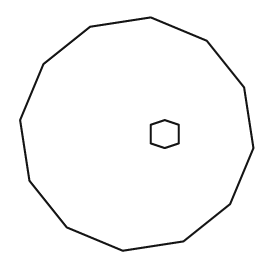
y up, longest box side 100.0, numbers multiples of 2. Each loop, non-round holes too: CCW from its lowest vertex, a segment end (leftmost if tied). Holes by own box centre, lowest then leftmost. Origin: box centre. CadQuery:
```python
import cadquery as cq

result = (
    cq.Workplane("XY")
    .moveTo(-6.0, -50.0)
    .lineTo(20.0, -46.0)
    .lineTo(40.0, -30.0)
    .lineTo(50.0, -6.0)
    .lineTo(46.0, 20.0)
    .lineTo(30.0, 40.0)
    .lineTo(6.0, 50.0)
    .lineTo(-20.0, 46.0)
    .lineTo(-40.0, 30.0)
    .lineTo(-50.0, 6.0)
    .lineTo(-46.0, -20.0)
    .lineTo(-30.0, -40.0)
    .close()
    .moveTo(12.0, -6.0)
    .lineTo(18.0, -4.0)
    .lineTo(18.0, 4.0)
    .lineTo(12.0, 6.0)
    .lineTo(6.0, 4.0)
    .lineTo(6.0, -4.0)
    .close()
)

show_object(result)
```